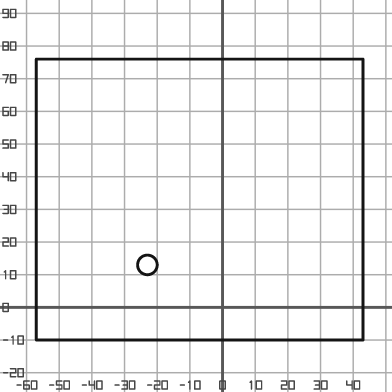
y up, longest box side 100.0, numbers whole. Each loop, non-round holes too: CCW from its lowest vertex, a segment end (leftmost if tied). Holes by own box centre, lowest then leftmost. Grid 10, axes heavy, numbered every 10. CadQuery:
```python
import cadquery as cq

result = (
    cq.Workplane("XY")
    .moveTo(-57.0, -10.0)
    .lineTo(43.0, -10.0)
    .lineTo(43.0, 76.0)
    .lineTo(-57.0, 76.0)
    .close()
    .moveTo(-23.0, 13.0)
    .circle(3.0)
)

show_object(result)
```